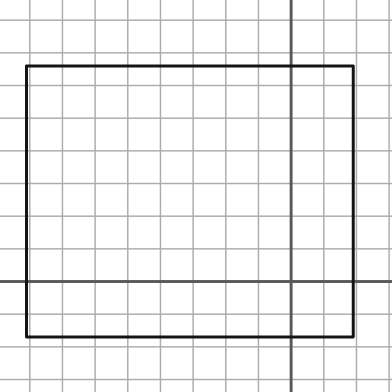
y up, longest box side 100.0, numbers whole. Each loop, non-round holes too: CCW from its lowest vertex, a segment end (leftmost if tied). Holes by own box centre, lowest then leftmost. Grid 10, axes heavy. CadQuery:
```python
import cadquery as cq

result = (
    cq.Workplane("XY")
    .moveTo(-81.0, -17.0)
    .lineTo(19.0, -17.0)
    .lineTo(19.0, 66.0)
    .lineTo(-81.0, 66.0)
    .close()
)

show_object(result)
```